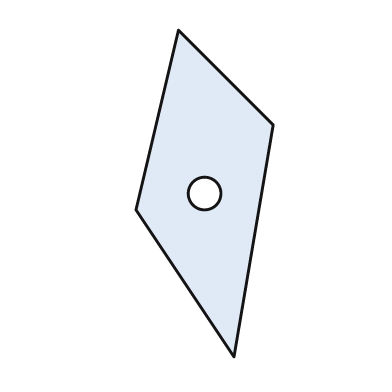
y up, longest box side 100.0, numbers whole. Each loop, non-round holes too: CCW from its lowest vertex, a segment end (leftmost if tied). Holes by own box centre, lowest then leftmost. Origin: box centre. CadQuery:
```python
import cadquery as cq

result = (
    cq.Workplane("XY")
    .moveTo(9.0, -50.0)
    .lineTo(21.0, 21.0)
    .lineTo(-8.0, 50.0)
    .lineTo(-21.0, -5.0)
    .close()
    .moveTo(0.0, 0.0)
    .circle(5.0)
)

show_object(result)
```